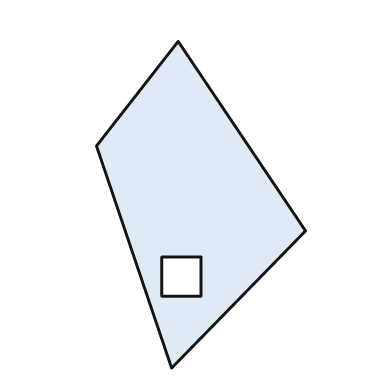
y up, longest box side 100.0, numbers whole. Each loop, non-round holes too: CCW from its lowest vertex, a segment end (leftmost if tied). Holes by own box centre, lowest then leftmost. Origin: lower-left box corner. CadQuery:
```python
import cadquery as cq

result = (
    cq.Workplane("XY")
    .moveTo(23.0, 0.0)
    .lineTo(64.0, 42.0)
    .lineTo(25.0, 100.0)
    .lineTo(0.0, 68.0)
    .close()
    .moveTo(20.0, 22.0)
    .lineTo(32.0, 22.0)
    .lineTo(32.0, 34.0)
    .lineTo(20.0, 34.0)
    .close()
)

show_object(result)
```